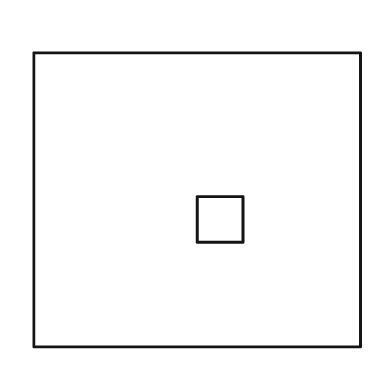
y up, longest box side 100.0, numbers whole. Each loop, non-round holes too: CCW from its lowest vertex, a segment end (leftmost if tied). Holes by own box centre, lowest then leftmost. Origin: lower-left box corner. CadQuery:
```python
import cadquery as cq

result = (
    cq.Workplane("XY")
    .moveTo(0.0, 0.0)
    .lineTo(100.0, 0.0)
    .lineTo(100.0, 90.0)
    .lineTo(0.0, 90.0)
    .close()
    .moveTo(50.0, 32.0)
    .lineTo(64.0, 32.0)
    .lineTo(64.0, 46.0)
    .lineTo(50.0, 46.0)
    .close()
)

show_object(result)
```